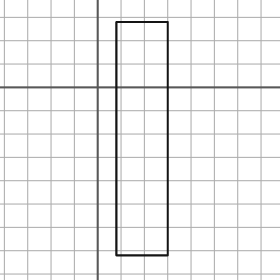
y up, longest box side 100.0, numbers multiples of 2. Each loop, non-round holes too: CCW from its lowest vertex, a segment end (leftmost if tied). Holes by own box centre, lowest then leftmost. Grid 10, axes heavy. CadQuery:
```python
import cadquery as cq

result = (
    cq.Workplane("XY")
    .moveTo(8.0, -72.0)
    .lineTo(30.0, -72.0)
    .lineTo(30.0, 28.0)
    .lineTo(8.0, 28.0)
    .close()
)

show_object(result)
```